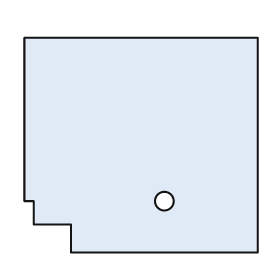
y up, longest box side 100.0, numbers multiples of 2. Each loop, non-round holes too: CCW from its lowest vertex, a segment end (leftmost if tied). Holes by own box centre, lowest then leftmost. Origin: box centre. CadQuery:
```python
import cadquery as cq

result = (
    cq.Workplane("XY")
    .moveTo(-30.0, -46.0)
    .lineTo(50.0, -46.0)
    .lineTo(50.0, 46.0)
    .lineTo(-50.0, 46.0)
    .lineTo(-50.0, -24.0)
    .lineTo(-46.0, -24.0)
    .lineTo(-46.0, -34.0)
    .lineTo(-30.0, -34.0)
    .close()
    .moveTo(10.0, -24.0)
    .circle(4.0)
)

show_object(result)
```